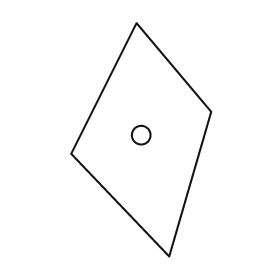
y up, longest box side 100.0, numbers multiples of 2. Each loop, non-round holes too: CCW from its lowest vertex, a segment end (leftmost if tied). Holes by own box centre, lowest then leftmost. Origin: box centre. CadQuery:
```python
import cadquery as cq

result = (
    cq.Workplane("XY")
    .moveTo(12.0, -50.0)
    .lineTo(30.0, 12.0)
    .lineTo(-2.0, 50.0)
    .lineTo(-30.0, -6.0)
    .close()
    .moveTo(0.0, 2.0)
    .circle(4.0)
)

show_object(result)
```